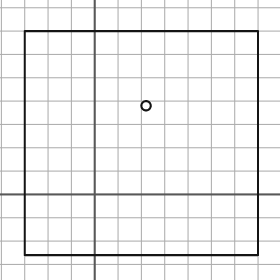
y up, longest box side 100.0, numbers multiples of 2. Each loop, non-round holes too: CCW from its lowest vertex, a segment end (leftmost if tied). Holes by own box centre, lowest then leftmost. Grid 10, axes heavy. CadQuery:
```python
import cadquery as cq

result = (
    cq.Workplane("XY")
    .moveTo(-30.0, -26.0)
    .lineTo(70.0, -26.0)
    .lineTo(70.0, 70.0)
    .lineTo(-30.0, 70.0)
    .close()
    .moveTo(22.0, 38.0)
    .circle(2.0)
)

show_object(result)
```